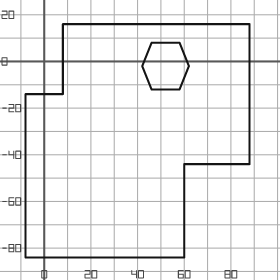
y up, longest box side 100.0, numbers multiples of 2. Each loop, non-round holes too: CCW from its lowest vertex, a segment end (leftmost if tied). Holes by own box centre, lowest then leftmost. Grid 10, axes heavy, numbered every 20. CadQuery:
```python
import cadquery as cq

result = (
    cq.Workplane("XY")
    .moveTo(-8.0, -84.0)
    .lineTo(60.0, -84.0)
    .lineTo(60.0, -44.0)
    .lineTo(88.0, -44.0)
    .lineTo(88.0, 16.0)
    .lineTo(8.0, 16.0)
    .lineTo(8.0, -14.0)
    .lineTo(-8.0, -14.0)
    .close()
    .moveTo(46.0, -12.0)
    .lineTo(58.0, -12.0)
    .lineTo(62.0, -2.0)
    .lineTo(58.0, 8.0)
    .lineTo(46.0, 8.0)
    .lineTo(42.0, -2.0)
    .close()
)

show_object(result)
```